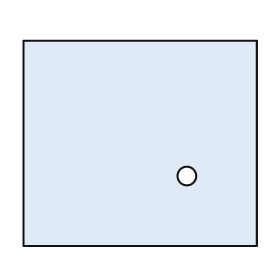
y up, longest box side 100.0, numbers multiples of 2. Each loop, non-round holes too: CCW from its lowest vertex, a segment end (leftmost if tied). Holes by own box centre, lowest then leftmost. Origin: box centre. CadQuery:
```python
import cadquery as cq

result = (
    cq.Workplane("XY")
    .moveTo(-50.0, -44.0)
    .lineTo(50.0, -44.0)
    .lineTo(50.0, 44.0)
    .lineTo(-50.0, 44.0)
    .close()
    .moveTo(20.0, -14.0)
    .circle(4.0)
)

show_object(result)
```